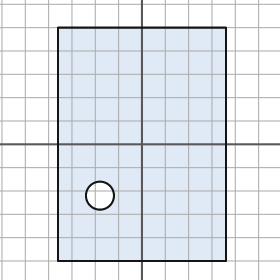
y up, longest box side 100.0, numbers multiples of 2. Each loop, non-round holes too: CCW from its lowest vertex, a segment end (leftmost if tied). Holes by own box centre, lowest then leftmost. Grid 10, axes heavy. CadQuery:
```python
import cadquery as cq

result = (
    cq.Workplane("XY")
    .moveTo(-36.0, -50.0)
    .lineTo(36.0, -50.0)
    .lineTo(36.0, 50.0)
    .lineTo(-36.0, 50.0)
    .close()
    .moveTo(-18.0, -22.0)
    .circle(6.0)
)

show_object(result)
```